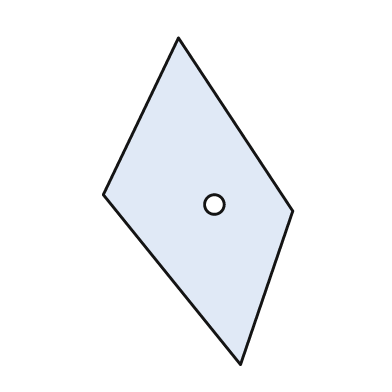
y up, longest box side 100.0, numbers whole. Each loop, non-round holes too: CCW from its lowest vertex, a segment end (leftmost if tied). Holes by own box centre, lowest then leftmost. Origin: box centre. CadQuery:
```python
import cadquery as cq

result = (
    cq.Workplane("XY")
    .moveTo(13.0, -50.0)
    .lineTo(29.0, -3.0)
    .lineTo(-6.0, 50.0)
    .lineTo(-29.0, 2.0)
    .close()
    .moveTo(5.0, -1.0)
    .circle(3.0)
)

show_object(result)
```